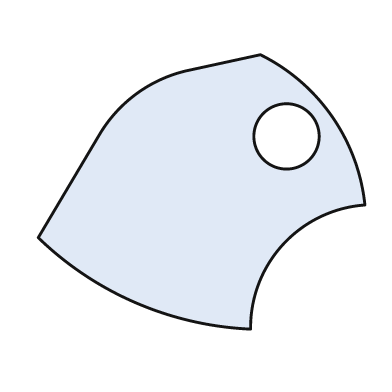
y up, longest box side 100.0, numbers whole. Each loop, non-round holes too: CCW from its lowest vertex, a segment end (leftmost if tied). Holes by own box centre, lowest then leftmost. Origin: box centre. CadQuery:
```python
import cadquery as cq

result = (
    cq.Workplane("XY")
    .moveTo(15.0, -42.0)
    .threePointArc((25.0, -16.0), (50.0, -4.0))
    .threePointArc((40.0, 23.0), (18.0, 42.0))
    .lineTo(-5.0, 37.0)
    .threePointArc((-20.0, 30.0), (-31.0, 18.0))
    .lineTo(-50.0, -14.0)
    .threePointArc((-20.0, -34.0), (15.0, -42.0))
    .close()
    .moveTo(26.0, 17.0)
    .circle(10.0)
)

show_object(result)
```